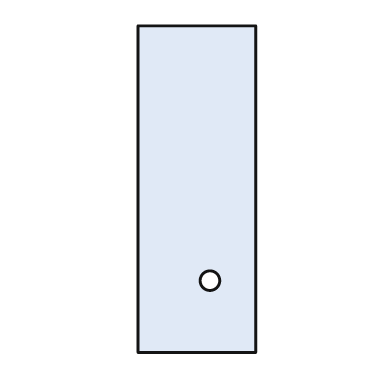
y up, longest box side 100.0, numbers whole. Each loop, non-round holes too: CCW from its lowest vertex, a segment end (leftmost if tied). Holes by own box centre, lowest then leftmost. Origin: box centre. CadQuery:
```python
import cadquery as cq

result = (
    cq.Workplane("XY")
    .moveTo(-18.0, -50.0)
    .lineTo(18.0, -50.0)
    .lineTo(18.0, 50.0)
    .lineTo(-18.0, 50.0)
    .close()
    .moveTo(4.0, -28.0)
    .circle(3.0)
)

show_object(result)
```